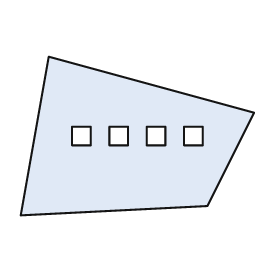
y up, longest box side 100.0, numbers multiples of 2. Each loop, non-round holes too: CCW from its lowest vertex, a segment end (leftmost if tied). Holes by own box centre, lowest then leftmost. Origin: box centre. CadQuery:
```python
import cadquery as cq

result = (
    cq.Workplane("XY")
    .moveTo(-50.0, -34.0)
    .lineTo(30.0, -30.0)
    .lineTo(50.0, 10.0)
    .lineTo(-38.0, 34.0)
    .close()
    .moveTo(-28.0, -4.0)
    .lineTo(-20.0, -4.0)
    .lineTo(-20.0, 4.0)
    .lineTo(-28.0, 4.0)
    .close()
    .moveTo(-12.0, -4.0)
    .lineTo(-4.0, -4.0)
    .lineTo(-4.0, 4.0)
    .lineTo(-12.0, 4.0)
    .close()
    .moveTo(4.0, -4.0)
    .lineTo(12.0, -4.0)
    .lineTo(12.0, 4.0)
    .lineTo(4.0, 4.0)
    .close()
    .moveTo(20.0, -4.0)
    .lineTo(28.0, -4.0)
    .lineTo(28.0, 4.0)
    .lineTo(20.0, 4.0)
    .close()
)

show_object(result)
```